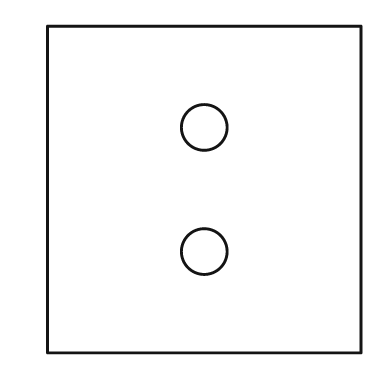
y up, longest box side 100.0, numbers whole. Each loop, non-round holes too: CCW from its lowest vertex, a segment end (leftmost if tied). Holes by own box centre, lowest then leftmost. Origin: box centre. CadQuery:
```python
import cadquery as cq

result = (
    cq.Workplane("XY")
    .moveTo(-48.0, -50.0)
    .lineTo(48.0, -50.0)
    .lineTo(48.0, 50.0)
    .lineTo(-48.0, 50.0)
    .close()
    .moveTo(0.0, -19.0)
    .circle(7.0)
    .moveTo(0.0, 19.0)
    .circle(7.0)
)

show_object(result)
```